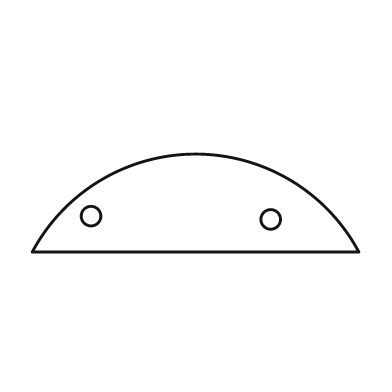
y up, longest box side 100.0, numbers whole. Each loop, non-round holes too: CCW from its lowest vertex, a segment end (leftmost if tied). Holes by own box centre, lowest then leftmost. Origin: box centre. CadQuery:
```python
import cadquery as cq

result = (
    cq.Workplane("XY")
    .moveTo(-50.0, -15.0)
    .lineTo(50.0, -15.0)
    .threePointArc((0.0, 15.0), (-50.0, -15.0))
    .close()
    .moveTo(23.0, -5.0)
    .circle(3.0)
    .moveTo(-32.0, -4.0)
    .circle(3.0)
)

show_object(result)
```